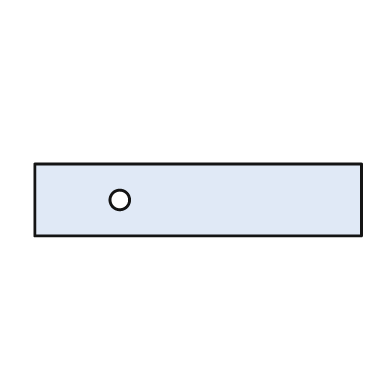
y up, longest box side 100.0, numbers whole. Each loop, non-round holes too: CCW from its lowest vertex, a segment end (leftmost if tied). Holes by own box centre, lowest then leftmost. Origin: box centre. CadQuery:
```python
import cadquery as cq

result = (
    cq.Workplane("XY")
    .moveTo(-50.0, -11.0)
    .lineTo(50.0, -11.0)
    .lineTo(50.0, 11.0)
    .lineTo(-50.0, 11.0)
    .close()
    .moveTo(-24.0, 0.0)
    .circle(3.0)
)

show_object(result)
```